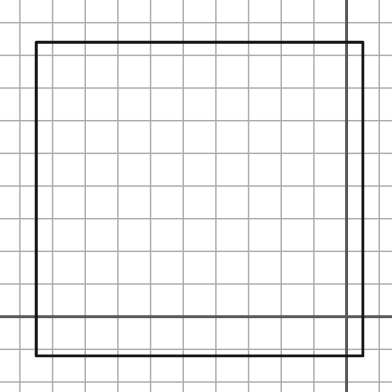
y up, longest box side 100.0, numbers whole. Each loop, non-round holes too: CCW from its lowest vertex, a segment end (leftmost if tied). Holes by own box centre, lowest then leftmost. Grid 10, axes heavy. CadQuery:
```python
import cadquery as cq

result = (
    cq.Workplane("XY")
    .moveTo(-95.0, -12.0)
    .lineTo(5.0, -12.0)
    .lineTo(5.0, 84.0)
    .lineTo(-95.0, 84.0)
    .close()
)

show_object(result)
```